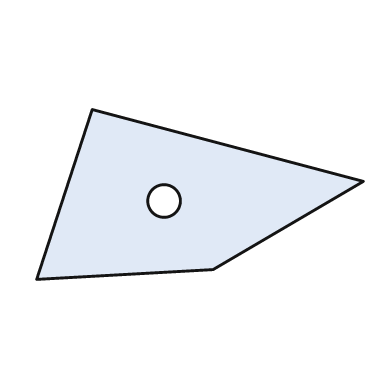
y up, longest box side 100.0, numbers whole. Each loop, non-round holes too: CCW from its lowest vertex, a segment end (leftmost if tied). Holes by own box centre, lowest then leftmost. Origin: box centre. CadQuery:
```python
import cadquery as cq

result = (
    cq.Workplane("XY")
    .moveTo(-50.0, -26.0)
    .lineTo(4.0, -23.0)
    .lineTo(50.0, 4.0)
    .lineTo(-33.0, 26.0)
    .close()
    .moveTo(-11.0, -2.0)
    .circle(5.0)
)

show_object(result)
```